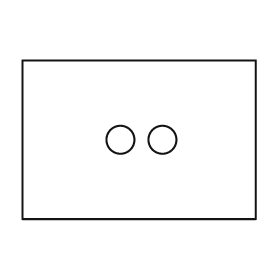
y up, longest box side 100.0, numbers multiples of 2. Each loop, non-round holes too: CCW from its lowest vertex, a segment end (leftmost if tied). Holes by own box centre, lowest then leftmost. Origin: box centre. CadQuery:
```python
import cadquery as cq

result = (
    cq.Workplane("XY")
    .moveTo(-50.0, -34.0)
    .lineTo(50.0, -34.0)
    .lineTo(50.0, 34.0)
    .lineTo(-50.0, 34.0)
    .close()
    .moveTo(-8.0, 0.0)
    .circle(6.0)
    .moveTo(10.0, 0.0)
    .circle(6.0)
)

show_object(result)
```